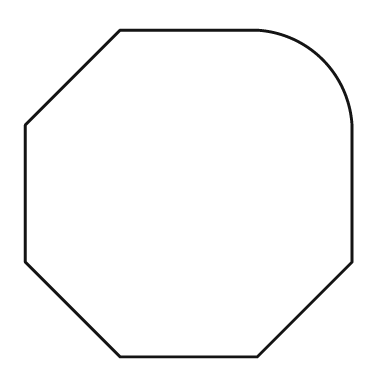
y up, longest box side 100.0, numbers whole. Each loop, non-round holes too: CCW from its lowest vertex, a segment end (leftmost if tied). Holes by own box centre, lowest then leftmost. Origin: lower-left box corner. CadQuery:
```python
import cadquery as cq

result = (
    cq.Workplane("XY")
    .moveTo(29.0, 0.0)
    .lineTo(71.0, 0.0)
    .lineTo(100.0, 29.0)
    .lineTo(100.0, 71.0)
    .threePointArc((91.0, 91.0), (71.0, 100.0))
    .lineTo(29.0, 100.0)
    .lineTo(0.0, 71.0)
    .lineTo(0.0, 29.0)
    .close()
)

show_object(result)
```